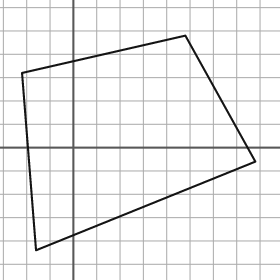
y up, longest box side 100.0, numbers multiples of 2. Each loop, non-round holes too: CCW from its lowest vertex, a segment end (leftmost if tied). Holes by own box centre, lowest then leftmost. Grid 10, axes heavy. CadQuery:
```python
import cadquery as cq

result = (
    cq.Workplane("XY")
    .moveTo(-16.0, -44.0)
    .lineTo(78.0, -6.0)
    .lineTo(48.0, 48.0)
    .lineTo(-22.0, 32.0)
    .close()
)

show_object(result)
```